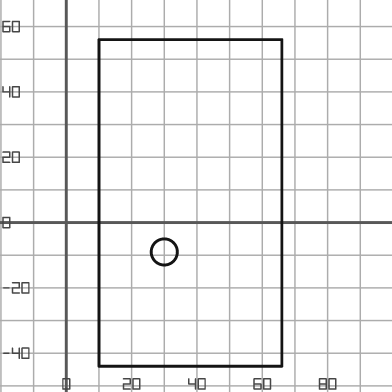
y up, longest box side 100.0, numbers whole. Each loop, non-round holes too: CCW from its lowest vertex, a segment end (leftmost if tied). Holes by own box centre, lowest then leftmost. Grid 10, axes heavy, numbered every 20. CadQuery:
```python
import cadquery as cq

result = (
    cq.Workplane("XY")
    .moveTo(10.0, -44.0)
    .lineTo(66.0, -44.0)
    .lineTo(66.0, 56.0)
    .lineTo(10.0, 56.0)
    .close()
    .moveTo(30.0, -9.0)
    .circle(4.0)
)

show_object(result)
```